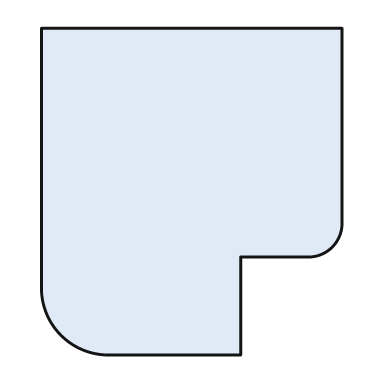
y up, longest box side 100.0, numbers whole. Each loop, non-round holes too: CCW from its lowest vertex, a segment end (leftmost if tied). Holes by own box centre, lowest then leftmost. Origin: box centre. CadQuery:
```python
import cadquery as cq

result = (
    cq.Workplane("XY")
    .moveTo(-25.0, -50.0)
    .lineTo(15.0, -50.0)
    .lineTo(15.0, -20.0)
    .lineTo(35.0, -20.0)
    .threePointArc((43.0, -17.0), (46.0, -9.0))
    .lineTo(46.0, 50.0)
    .lineTo(-46.0, 50.0)
    .lineTo(-46.0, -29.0)
    .threePointArc((-40.0, -44.0), (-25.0, -50.0))
    .close()
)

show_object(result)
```